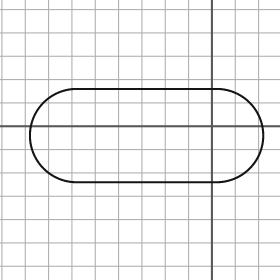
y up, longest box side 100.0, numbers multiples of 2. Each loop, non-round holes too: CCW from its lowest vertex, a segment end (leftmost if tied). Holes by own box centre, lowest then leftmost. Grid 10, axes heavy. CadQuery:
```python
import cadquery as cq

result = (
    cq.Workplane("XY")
    .moveTo(-58.0, -24.0)
    .lineTo(2.0, -24.0)
    .threePointArc((22.0, -4.0), (2.0, 16.0))
    .lineTo(-58.0, 16.0)
    .threePointArc((-78.0, -4.0), (-58.0, -24.0))
    .close()
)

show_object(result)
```